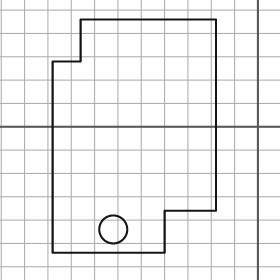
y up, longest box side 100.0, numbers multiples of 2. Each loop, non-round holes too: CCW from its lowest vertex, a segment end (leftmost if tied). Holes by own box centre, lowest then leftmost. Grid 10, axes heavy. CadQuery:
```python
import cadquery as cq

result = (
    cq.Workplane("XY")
    .moveTo(-88.0, -54.0)
    .lineTo(-40.0, -54.0)
    .lineTo(-40.0, -36.0)
    .lineTo(-18.0, -36.0)
    .lineTo(-18.0, 46.0)
    .lineTo(-76.0, 46.0)
    .lineTo(-76.0, 28.0)
    .lineTo(-88.0, 28.0)
    .close()
    .moveTo(-62.0, -44.0)
    .circle(6.0)
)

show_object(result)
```